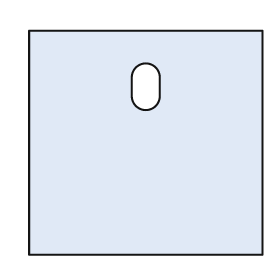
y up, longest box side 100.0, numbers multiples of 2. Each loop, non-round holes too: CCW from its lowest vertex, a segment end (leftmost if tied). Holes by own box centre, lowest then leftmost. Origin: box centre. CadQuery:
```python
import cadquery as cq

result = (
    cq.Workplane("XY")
    .moveTo(-50.0, -48.0)
    .lineTo(50.0, -48.0)
    .lineTo(50.0, 48.0)
    .lineTo(-50.0, 48.0)
    .close()
    .moveTo(-6.0, 20.0)
    .threePointArc((0.0, 14.0), (6.0, 20.0))
    .lineTo(6.0, 28.0)
    .threePointArc((0.0, 34.0), (-6.0, 28.0))
    .close()
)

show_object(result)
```